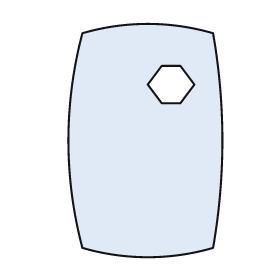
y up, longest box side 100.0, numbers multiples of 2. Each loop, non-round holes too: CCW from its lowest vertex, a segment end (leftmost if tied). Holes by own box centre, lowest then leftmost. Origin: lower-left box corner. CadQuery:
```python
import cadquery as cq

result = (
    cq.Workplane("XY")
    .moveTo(6.0, 4.0)
    .threePointArc((34.0, 0.0), (62.0, 4.0))
    .threePointArc((66.0, 50.0), (62.0, 96.0))
    .threePointArc((34.0, 100.0), (6.0, 96.0))
    .threePointArc((0.0, 50.0), (6.0, 4.0))
    .close()
    .moveTo(40.0, 66.0)
    .lineTo(48.0, 66.0)
    .lineTo(54.0, 74.0)
    .lineTo(48.0, 82.0)
    .lineTo(40.0, 82.0)
    .lineTo(34.0, 74.0)
    .close()
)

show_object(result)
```